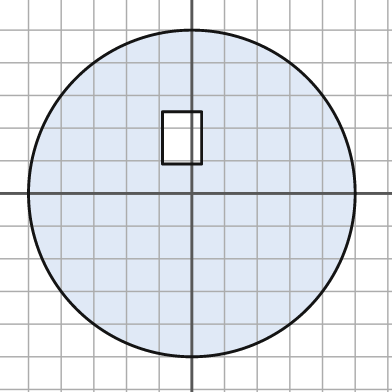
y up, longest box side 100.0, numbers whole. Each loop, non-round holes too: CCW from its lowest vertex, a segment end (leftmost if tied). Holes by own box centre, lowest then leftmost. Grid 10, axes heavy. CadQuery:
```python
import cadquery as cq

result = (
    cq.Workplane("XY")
    .moveTo(0.0, 0.0)
    .circle(50.0)
    .moveTo(-9.0, 9.0)
    .lineTo(3.0, 9.0)
    .lineTo(3.0, 25.0)
    .lineTo(-9.0, 25.0)
    .close()
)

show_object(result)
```